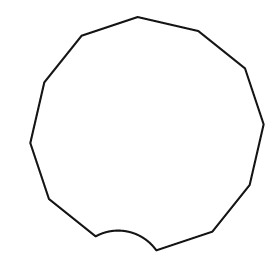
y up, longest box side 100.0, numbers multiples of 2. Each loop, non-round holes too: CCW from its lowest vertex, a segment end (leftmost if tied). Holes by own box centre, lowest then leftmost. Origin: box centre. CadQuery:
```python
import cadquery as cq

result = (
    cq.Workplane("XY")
    .moveTo(4.0, -50.0)
    .lineTo(28.0, -42.0)
    .lineTo(44.0, -22.0)
    .lineTo(50.0, 4.0)
    .lineTo(42.0, 28.0)
    .lineTo(22.0, 44.0)
    .lineTo(-4.0, 50.0)
    .lineTo(-28.0, 42.0)
    .lineTo(-44.0, 22.0)
    .lineTo(-50.0, -4.0)
    .lineTo(-42.0, -28.0)
    .lineTo(-22.0, -44.0)
    .threePointArc((-8.0, -42.0), (4.0, -50.0))
    .close()
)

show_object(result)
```